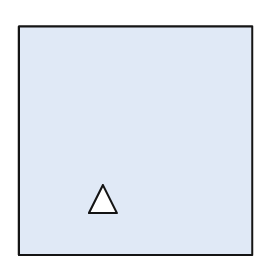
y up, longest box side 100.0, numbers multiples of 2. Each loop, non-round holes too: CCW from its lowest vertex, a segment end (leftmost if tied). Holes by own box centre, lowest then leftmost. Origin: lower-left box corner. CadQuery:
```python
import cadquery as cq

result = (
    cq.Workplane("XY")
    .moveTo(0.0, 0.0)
    .lineTo(100.0, 0.0)
    .lineTo(100.0, 98.0)
    .lineTo(0.0, 98.0)
    .close()
    .moveTo(30.0, 18.0)
    .lineTo(42.0, 18.0)
    .lineTo(36.0, 30.0)
    .close()
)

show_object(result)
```